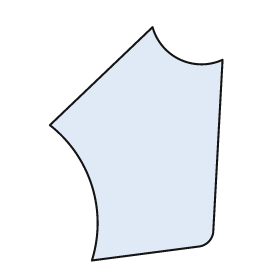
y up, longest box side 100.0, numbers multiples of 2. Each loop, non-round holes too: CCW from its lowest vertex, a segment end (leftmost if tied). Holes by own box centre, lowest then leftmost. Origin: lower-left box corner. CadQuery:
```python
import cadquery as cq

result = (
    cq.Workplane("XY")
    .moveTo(18.0, 0.0)
    .lineTo(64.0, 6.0)
    .threePointArc((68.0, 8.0), (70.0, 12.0))
    .lineTo(74.0, 86.0)
    .threePointArc((56.0, 86.0), (44.0, 100.0))
    .lineTo(0.0, 58.0)
    .threePointArc((18.0, 32.0), (18.0, 0.0))
    .close()
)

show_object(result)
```